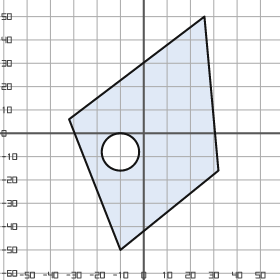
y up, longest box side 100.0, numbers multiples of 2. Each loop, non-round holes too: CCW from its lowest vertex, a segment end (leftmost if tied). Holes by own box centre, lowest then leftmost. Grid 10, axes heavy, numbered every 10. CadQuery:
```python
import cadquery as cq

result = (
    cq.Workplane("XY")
    .moveTo(-10.0, -50.0)
    .lineTo(32.0, -16.0)
    .lineTo(26.0, 50.0)
    .lineTo(-32.0, 6.0)
    .close()
    .moveTo(-10.0, -8.0)
    .circle(8.0)
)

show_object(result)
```